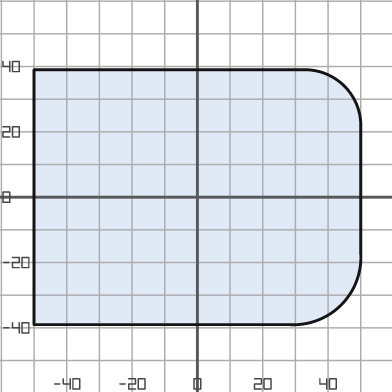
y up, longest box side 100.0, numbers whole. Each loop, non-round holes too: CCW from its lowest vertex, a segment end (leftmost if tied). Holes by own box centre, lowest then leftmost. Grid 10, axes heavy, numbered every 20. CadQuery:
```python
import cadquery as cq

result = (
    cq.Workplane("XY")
    .moveTo(-50.0, -39.0)
    .lineTo(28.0, -39.0)
    .threePointArc((44.0, -33.0), (50.0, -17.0))
    .lineTo(50.0, 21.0)
    .threePointArc((45.0, 34.0), (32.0, 39.0))
    .lineTo(-50.0, 39.0)
    .close()
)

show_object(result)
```